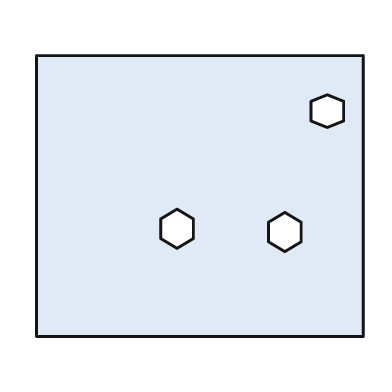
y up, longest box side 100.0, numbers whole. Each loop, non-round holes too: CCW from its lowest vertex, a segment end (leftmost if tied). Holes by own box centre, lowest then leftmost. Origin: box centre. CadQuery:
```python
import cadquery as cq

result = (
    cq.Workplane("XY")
    .moveTo(-50.0, -43.0)
    .lineTo(50.0, -43.0)
    .lineTo(50.0, 43.0)
    .lineTo(-50.0, 43.0)
    .close()
    .moveTo(26.0, -17.0)
    .lineTo(31.0, -14.0)
    .lineTo(31.0, -8.0)
    .lineTo(26.0, -5.0)
    .lineTo(21.0, -8.0)
    .lineTo(21.0, -14.0)
    .close()
    .moveTo(-7.0, -16.0)
    .lineTo(-2.0, -13.0)
    .lineTo(-2.0, -7.0)
    .lineTo(-7.0, -4.0)
    .lineTo(-12.0, -7.0)
    .lineTo(-12.0, -13.0)
    .close()
    .moveTo(39.0, 21.0)
    .lineTo(44.0, 23.0)
    .lineTo(44.0, 29.0)
    .lineTo(39.0, 31.0)
    .lineTo(34.0, 29.0)
    .lineTo(34.0, 23.0)
    .close()
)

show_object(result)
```